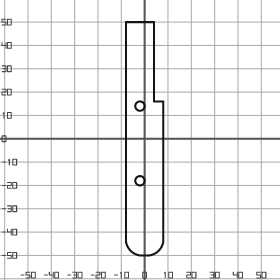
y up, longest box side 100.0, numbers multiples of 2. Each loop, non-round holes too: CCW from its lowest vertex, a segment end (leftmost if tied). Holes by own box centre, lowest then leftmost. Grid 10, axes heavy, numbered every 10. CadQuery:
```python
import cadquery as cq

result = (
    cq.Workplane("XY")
    .moveTo(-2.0, -50.0)
    .lineTo(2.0, -50.0)
    .threePointArc((6.0, -48.0), (8.0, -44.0))
    .lineTo(8.0, 16.0)
    .lineTo(4.0, 16.0)
    .lineTo(4.0, 50.0)
    .lineTo(-8.0, 50.0)
    .lineTo(-8.0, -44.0)
    .threePointArc((-6.0, -48.0), (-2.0, -50.0))
    .close()
    .moveTo(-2.0, -18.0)
    .circle(2.0)
    .moveTo(-2.0, 14.0)
    .circle(2.0)
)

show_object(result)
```